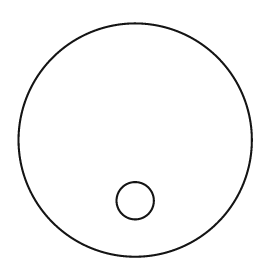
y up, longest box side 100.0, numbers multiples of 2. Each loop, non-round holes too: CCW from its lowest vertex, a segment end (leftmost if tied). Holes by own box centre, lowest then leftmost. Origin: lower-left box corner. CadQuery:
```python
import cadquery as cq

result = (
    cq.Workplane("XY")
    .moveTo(50.0, 50.0)
    .circle(50.0)
    .moveTo(50.0, 24.0)
    .circle(8.0)
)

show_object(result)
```